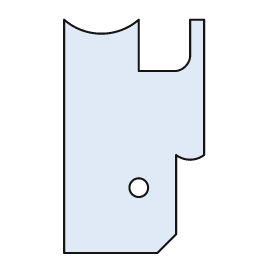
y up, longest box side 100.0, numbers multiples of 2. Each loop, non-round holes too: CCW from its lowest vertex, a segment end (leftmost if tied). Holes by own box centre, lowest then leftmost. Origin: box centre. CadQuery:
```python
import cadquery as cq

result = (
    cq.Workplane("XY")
    .moveTo(-30.0, -50.0)
    .lineTo(10.0, -50.0)
    .lineTo(18.0, -42.0)
    .lineTo(18.0, -8.0)
    .threePointArc((24.0, -10.0), (30.0, -8.0))
    .lineTo(30.0, 50.0)
    .lineTo(24.0, 50.0)
    .lineTo(24.0, 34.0)
    .threePointArc((22.0, 30.0), (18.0, 28.0))
    .lineTo(2.0, 28.0)
    .lineTo(2.0, 50.0)
    .threePointArc((-14.0, 44.0), (-30.0, 50.0))
    .close()
    .moveTo(2.0, -22.0)
    .circle(4.0)
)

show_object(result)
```